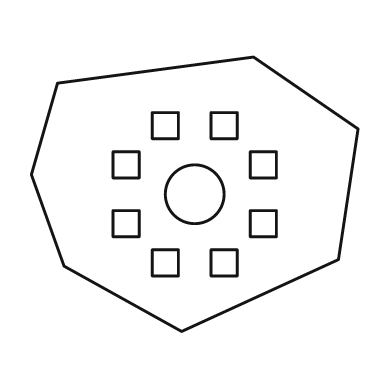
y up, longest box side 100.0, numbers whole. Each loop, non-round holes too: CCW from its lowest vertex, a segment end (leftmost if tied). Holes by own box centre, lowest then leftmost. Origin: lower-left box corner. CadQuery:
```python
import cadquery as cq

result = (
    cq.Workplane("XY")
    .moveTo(46.0, 0.0)
    .lineTo(94.0, 22.0)
    .lineTo(100.0, 62.0)
    .lineTo(68.0, 84.0)
    .lineTo(8.0, 76.0)
    .lineTo(0.0, 48.0)
    .lineTo(10.0, 20.0)
    .close()
    .moveTo(37.0, 17.0)
    .lineTo(45.0, 17.0)
    .lineTo(45.0, 25.0)
    .lineTo(37.0, 25.0)
    .close()
    .moveTo(55.0, 17.0)
    .lineTo(63.0, 17.0)
    .lineTo(63.0, 25.0)
    .lineTo(55.0, 25.0)
    .close()
    .moveTo(25.0, 29.0)
    .lineTo(33.0, 29.0)
    .lineTo(33.0, 37.0)
    .lineTo(25.0, 37.0)
    .close()
    .moveTo(67.0, 29.0)
    .lineTo(75.0, 29.0)
    .lineTo(75.0, 37.0)
    .lineTo(67.0, 37.0)
    .close()
    .moveTo(50.0, 42.0)
    .circle(9.0)
    .moveTo(25.0, 47.0)
    .lineTo(33.0, 47.0)
    .lineTo(33.0, 55.0)
    .lineTo(25.0, 55.0)
    .close()
    .moveTo(67.0, 47.0)
    .lineTo(75.0, 47.0)
    .lineTo(75.0, 55.0)
    .lineTo(67.0, 55.0)
    .close()
    .moveTo(37.0, 59.0)
    .lineTo(45.0, 59.0)
    .lineTo(45.0, 67.0)
    .lineTo(37.0, 67.0)
    .close()
    .moveTo(55.0, 59.0)
    .lineTo(63.0, 59.0)
    .lineTo(63.0, 67.0)
    .lineTo(55.0, 67.0)
    .close()
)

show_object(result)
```